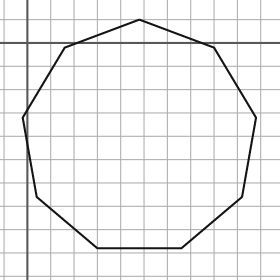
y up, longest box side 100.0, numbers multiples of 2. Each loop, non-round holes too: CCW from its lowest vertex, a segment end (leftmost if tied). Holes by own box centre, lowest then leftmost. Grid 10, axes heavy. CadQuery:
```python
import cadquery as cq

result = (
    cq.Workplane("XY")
    .moveTo(30.0, -88.0)
    .lineTo(66.0, -88.0)
    .lineTo(92.0, -66.0)
    .lineTo(98.0, -32.0)
    .lineTo(80.0, -2.0)
    .lineTo(48.0, 10.0)
    .lineTo(16.0, -2.0)
    .lineTo(-2.0, -32.0)
    .lineTo(4.0, -66.0)
    .close()
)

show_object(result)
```